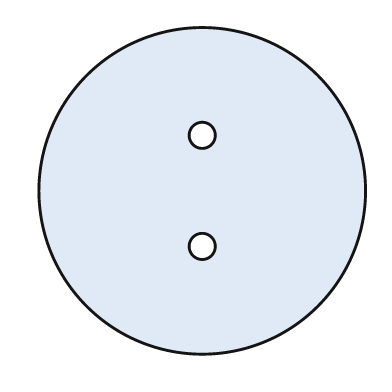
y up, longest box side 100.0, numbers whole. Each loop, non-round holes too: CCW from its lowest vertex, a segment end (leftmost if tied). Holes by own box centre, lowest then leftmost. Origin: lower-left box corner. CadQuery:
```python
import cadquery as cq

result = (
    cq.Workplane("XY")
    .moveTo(50.0, 50.0)
    .circle(50.0)
    .moveTo(50.0, 33.0)
    .circle(4.0)
    .moveTo(50.0, 67.0)
    .circle(4.0)
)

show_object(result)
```